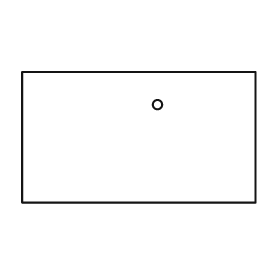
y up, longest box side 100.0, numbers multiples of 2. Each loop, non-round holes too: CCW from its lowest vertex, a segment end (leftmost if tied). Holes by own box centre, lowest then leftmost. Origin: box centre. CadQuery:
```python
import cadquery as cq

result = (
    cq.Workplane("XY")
    .moveTo(-50.0, -28.0)
    .lineTo(50.0, -28.0)
    .lineTo(50.0, 28.0)
    .lineTo(-50.0, 28.0)
    .close()
    .moveTo(8.0, 14.0)
    .circle(2.0)
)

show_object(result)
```